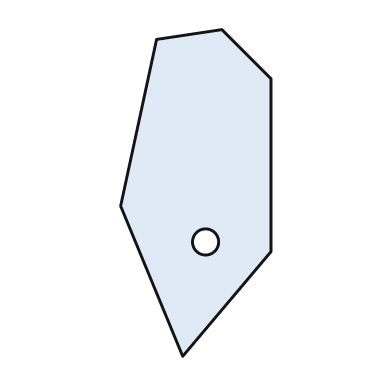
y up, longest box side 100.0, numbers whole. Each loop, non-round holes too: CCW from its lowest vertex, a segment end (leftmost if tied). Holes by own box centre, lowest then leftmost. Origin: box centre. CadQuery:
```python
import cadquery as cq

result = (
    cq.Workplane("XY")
    .moveTo(-4.0, -50.0)
    .lineTo(23.0, -18.0)
    .lineTo(23.0, 35.0)
    .lineTo(8.0, 50.0)
    .lineTo(-12.0, 47.0)
    .lineTo(-23.0, -4.0)
    .close()
    .moveTo(3.0, -15.0)
    .circle(4.0)
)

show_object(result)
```